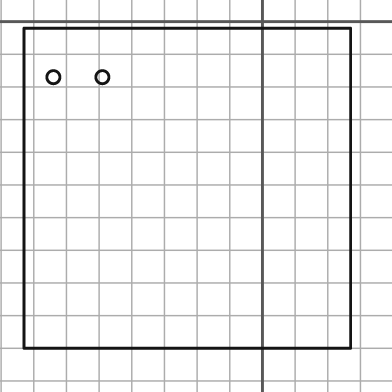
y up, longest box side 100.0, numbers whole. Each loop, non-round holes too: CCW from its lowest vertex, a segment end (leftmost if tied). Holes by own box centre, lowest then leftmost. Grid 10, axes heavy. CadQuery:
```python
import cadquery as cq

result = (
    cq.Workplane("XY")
    .moveTo(-73.0, -100.0)
    .lineTo(27.0, -100.0)
    .lineTo(27.0, -2.0)
    .lineTo(-73.0, -2.0)
    .close()
    .moveTo(-64.0, -17.0)
    .circle(2.0)
    .moveTo(-49.0, -17.0)
    .circle(2.0)
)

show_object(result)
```